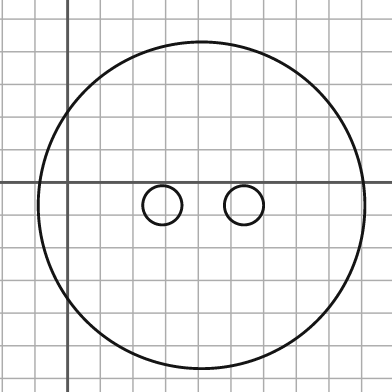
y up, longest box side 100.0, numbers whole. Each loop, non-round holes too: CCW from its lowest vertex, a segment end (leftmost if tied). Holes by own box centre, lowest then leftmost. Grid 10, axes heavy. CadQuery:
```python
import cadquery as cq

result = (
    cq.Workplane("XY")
    .moveTo(41.0, -7.0)
    .circle(50.0)
    .moveTo(29.0, -7.0)
    .circle(6.0)
    .moveTo(54.0, -7.0)
    .circle(6.0)
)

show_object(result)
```